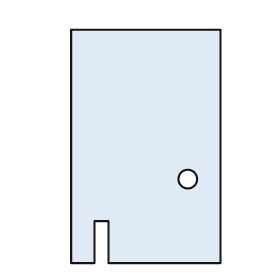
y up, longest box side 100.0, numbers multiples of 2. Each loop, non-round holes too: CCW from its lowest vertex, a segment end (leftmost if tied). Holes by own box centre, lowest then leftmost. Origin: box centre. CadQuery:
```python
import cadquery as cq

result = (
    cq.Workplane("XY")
    .moveTo(-32.0, -50.0)
    .lineTo(-22.0, -50.0)
    .lineTo(-22.0, -32.0)
    .lineTo(-16.0, -32.0)
    .lineTo(-16.0, -50.0)
    .lineTo(32.0, -50.0)
    .lineTo(32.0, 50.0)
    .lineTo(-32.0, 50.0)
    .close()
    .moveTo(18.0, -14.0)
    .circle(4.0)
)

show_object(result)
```